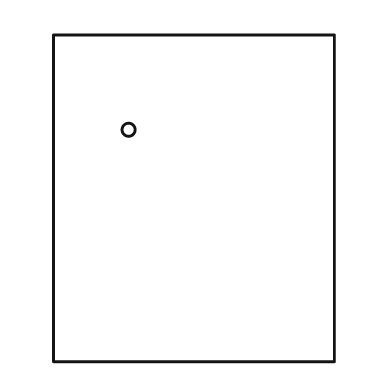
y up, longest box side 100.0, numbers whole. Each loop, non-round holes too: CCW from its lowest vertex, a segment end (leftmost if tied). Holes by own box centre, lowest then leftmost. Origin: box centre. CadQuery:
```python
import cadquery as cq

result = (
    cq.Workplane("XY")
    .moveTo(-43.0, -50.0)
    .lineTo(43.0, -50.0)
    .lineTo(43.0, 50.0)
    .lineTo(-43.0, 50.0)
    .close()
    .moveTo(-20.0, 21.0)
    .circle(2.0)
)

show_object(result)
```